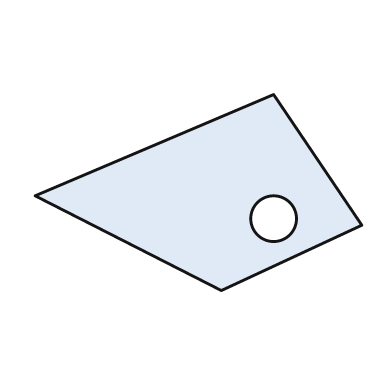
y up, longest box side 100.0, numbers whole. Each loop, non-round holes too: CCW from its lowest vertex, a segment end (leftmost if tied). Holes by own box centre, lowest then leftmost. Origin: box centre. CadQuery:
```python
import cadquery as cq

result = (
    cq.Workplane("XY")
    .moveTo(7.0, -30.0)
    .lineTo(50.0, -10.0)
    .lineTo(23.0, 30.0)
    .lineTo(-50.0, -1.0)
    .close()
    .moveTo(23.0, -8.0)
    .circle(7.0)
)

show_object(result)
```